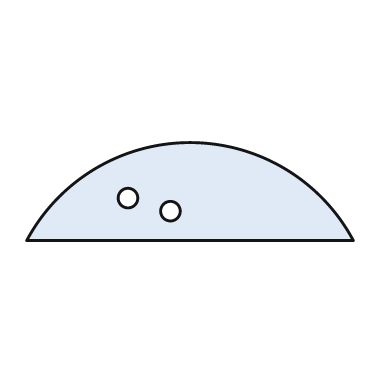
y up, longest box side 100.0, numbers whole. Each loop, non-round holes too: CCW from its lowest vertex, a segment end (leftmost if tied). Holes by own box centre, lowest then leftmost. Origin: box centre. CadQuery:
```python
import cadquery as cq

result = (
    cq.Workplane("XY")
    .moveTo(-50.0, -15.0)
    .lineTo(50.0, -15.0)
    .threePointArc((0.0, 15.0), (-50.0, -15.0))
    .close()
    .moveTo(-6.0, -6.0)
    .circle(3.0)
    .moveTo(-19.0, -2.0)
    .circle(3.0)
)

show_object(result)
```